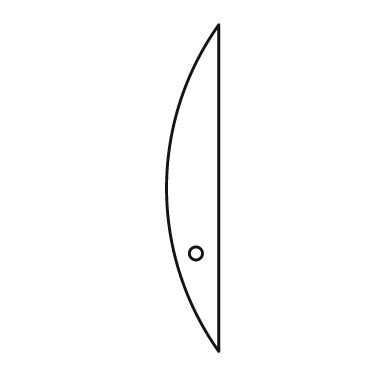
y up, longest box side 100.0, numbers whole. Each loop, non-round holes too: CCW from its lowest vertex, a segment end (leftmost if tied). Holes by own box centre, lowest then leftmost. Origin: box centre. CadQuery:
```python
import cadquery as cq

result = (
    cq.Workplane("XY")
    .moveTo(8.0, -50.0)
    .lineTo(8.0, 50.0)
    .threePointArc((-8.0, 0.0), (8.0, -50.0))
    .close()
    .moveTo(1.0, -20.0)
    .circle(2.0)
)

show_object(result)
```